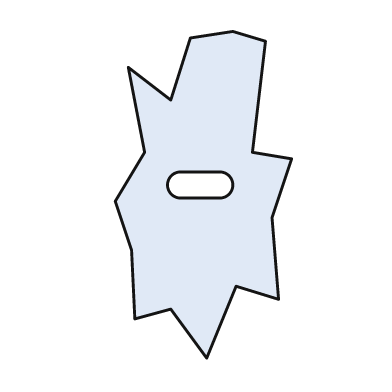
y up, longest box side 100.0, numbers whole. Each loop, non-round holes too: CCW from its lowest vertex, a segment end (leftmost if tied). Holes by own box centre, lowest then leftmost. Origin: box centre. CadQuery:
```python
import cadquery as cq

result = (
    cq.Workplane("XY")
    .moveTo(1.0, -50.0)
    .lineTo(10.0, -28.0)
    .lineTo(23.0, -32.0)
    .lineTo(21.0, -7.0)
    .lineTo(27.0, 11.0)
    .lineTo(15.0, 13.0)
    .lineTo(19.0, 47.0)
    .lineTo(9.0, 50.0)
    .lineTo(-4.0, 48.0)
    .lineTo(-10.0, 29.0)
    .lineTo(-23.0, 39.0)
    .lineTo(-18.0, 13.0)
    .lineTo(-27.0, -2.0)
    .lineTo(-22.0, -17.0)
    .lineTo(-21.0, -38.0)
    .lineTo(-10.0, -35.0)
    .close()
    .moveTo(-7.0, -1.0)
    .lineTo(5.0, -1.0)
    .threePointArc((9.0, 3.0), (5.0, 7.0))
    .lineTo(-7.0, 7.0)
    .threePointArc((-11.0, 3.0), (-7.0, -1.0))
    .close()
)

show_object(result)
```